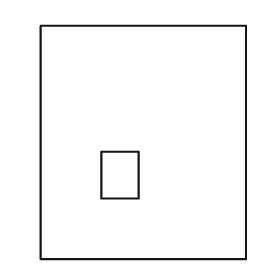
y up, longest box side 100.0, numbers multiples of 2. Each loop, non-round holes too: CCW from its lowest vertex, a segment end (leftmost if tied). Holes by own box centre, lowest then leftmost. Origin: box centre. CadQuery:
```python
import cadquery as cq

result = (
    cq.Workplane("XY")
    .moveTo(-44.0, -50.0)
    .lineTo(44.0, -50.0)
    .lineTo(44.0, 50.0)
    .lineTo(-44.0, 50.0)
    .close()
    .moveTo(-18.0, -24.0)
    .lineTo(-2.0, -24.0)
    .lineTo(-2.0, -4.0)
    .lineTo(-18.0, -4.0)
    .close()
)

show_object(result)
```